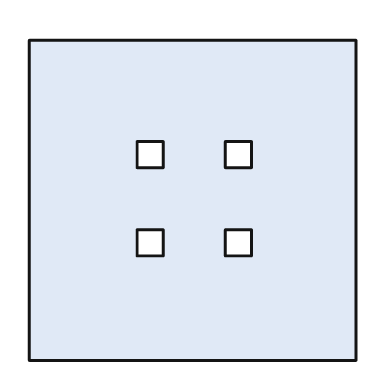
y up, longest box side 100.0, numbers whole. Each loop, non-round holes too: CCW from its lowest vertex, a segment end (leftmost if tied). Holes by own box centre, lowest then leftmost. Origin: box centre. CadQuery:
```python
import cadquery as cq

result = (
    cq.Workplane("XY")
    .moveTo(-50.0, -49.0)
    .lineTo(50.0, -49.0)
    .lineTo(50.0, 49.0)
    .lineTo(-50.0, 49.0)
    .close()
    .moveTo(-17.0, -17.0)
    .lineTo(-9.0, -17.0)
    .lineTo(-9.0, -9.0)
    .lineTo(-17.0, -9.0)
    .close()
    .moveTo(10.0, -17.0)
    .lineTo(18.0, -17.0)
    .lineTo(18.0, -9.0)
    .lineTo(10.0, -9.0)
    .close()
    .moveTo(-17.0, 10.0)
    .lineTo(-9.0, 10.0)
    .lineTo(-9.0, 18.0)
    .lineTo(-17.0, 18.0)
    .close()
    .moveTo(10.0, 10.0)
    .lineTo(18.0, 10.0)
    .lineTo(18.0, 18.0)
    .lineTo(10.0, 18.0)
    .close()
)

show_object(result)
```